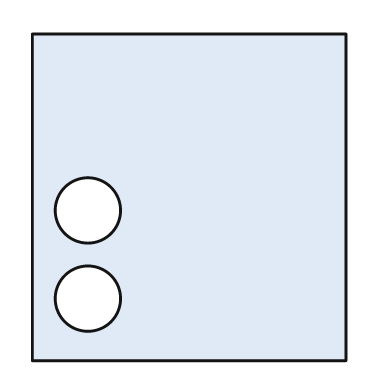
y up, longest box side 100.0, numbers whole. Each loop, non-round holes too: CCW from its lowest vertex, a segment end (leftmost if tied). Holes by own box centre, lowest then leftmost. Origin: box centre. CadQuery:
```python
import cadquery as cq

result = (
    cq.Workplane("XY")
    .moveTo(-48.0, -50.0)
    .lineTo(48.0, -50.0)
    .lineTo(48.0, 50.0)
    .lineTo(-48.0, 50.0)
    .close()
    .moveTo(-31.0, -31.0)
    .circle(10.0)
    .moveTo(-31.0, -4.0)
    .circle(10.0)
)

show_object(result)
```